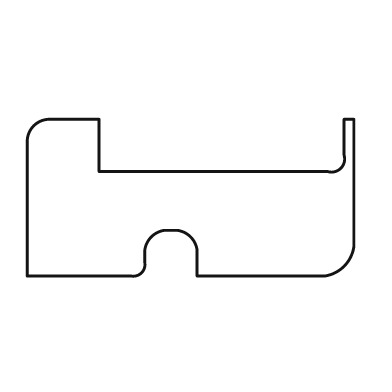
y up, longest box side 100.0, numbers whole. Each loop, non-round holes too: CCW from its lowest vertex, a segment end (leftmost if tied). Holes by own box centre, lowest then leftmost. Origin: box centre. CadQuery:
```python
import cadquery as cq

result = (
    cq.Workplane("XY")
    .moveTo(-50.0, -24.0)
    .lineTo(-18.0, -24.0)
    .threePointArc((-15.0, -23.0), (-14.0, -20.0))
    .lineTo(-14.0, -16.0)
    .threePointArc((-12.0, -12.0), (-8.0, -10.0))
    .lineTo(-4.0, -10.0)
    .threePointArc((0.0, -12.0), (2.0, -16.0))
    .lineTo(2.0, -24.0)
    .lineTo(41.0, -24.0)
    .threePointArc((47.0, -21.0), (50.0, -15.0))
    .lineTo(50.0, 24.0)
    .lineTo(47.0, 24.0)
    .lineTo(47.0, 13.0)
    .threePointArc((46.0, 9.0), (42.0, 8.0))
    .lineTo(-28.0, 8.0)
    .lineTo(-28.0, 24.0)
    .lineTo(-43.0, 24.0)
    .threePointArc((-48.0, 22.0), (-50.0, 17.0))
    .close()
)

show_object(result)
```